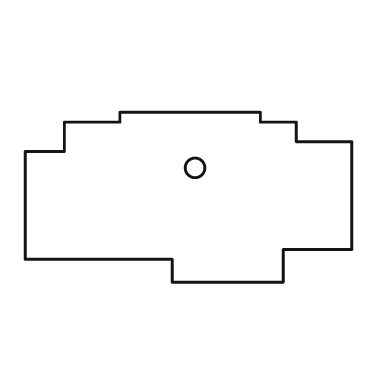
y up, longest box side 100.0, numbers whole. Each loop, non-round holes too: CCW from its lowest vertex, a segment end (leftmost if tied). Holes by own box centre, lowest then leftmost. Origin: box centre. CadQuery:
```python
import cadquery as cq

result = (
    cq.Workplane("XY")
    .moveTo(-5.0, -26.0)
    .lineTo(29.0, -26.0)
    .lineTo(29.0, -16.0)
    .lineTo(50.0, -16.0)
    .lineTo(50.0, 17.0)
    .lineTo(33.0, 17.0)
    .lineTo(33.0, 23.0)
    .lineTo(22.0, 23.0)
    .lineTo(22.0, 26.0)
    .lineTo(-21.0, 26.0)
    .lineTo(-21.0, 23.0)
    .lineTo(-38.0, 23.0)
    .lineTo(-38.0, 14.0)
    .lineTo(-50.0, 14.0)
    .lineTo(-50.0, -19.0)
    .lineTo(-5.0, -19.0)
    .close()
    .moveTo(2.0, 9.0)
    .circle(3.0)
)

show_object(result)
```